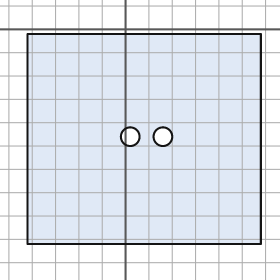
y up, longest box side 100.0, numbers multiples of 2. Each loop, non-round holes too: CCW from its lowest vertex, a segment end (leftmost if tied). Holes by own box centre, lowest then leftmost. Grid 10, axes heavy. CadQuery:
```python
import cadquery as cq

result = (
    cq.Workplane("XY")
    .moveTo(-42.0, -92.0)
    .lineTo(58.0, -92.0)
    .lineTo(58.0, -2.0)
    .lineTo(-42.0, -2.0)
    .close()
    .moveTo(2.0, -46.0)
    .circle(4.0)
    .moveTo(16.0, -46.0)
    .circle(4.0)
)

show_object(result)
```